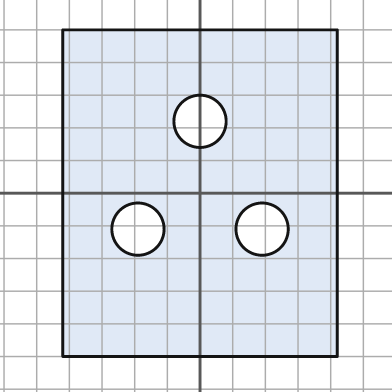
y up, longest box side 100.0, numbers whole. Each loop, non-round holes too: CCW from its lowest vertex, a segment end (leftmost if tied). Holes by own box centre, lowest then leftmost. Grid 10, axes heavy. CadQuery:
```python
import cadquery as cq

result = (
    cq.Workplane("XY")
    .moveTo(-42.0, -50.0)
    .lineTo(42.0, -50.0)
    .lineTo(42.0, 50.0)
    .lineTo(-42.0, 50.0)
    .close()
    .moveTo(-19.0, -11.0)
    .circle(8.0)
    .moveTo(19.0, -11.0)
    .circle(8.0)
    .moveTo(0.0, 22.0)
    .circle(8.0)
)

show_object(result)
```